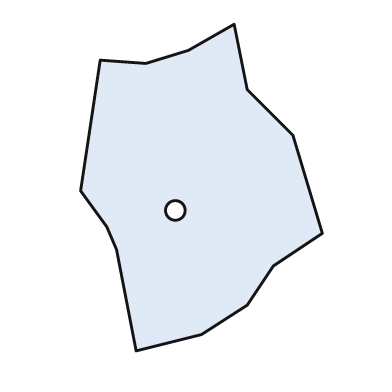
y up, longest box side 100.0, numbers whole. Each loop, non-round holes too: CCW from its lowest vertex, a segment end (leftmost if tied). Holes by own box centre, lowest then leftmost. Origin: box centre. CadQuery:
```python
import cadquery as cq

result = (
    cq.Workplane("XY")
    .moveTo(-20.0, -50.0)
    .lineTo(0.0, -45.0)
    .lineTo(14.0, -36.0)
    .lineTo(22.0, -24.0)
    .lineTo(37.0, -14.0)
    .lineTo(28.0, 16.0)
    .lineTo(14.0, 30.0)
    .lineTo(10.0, 50.0)
    .lineTo(-4.0, 42.0)
    .lineTo(-17.0, 38.0)
    .lineTo(-31.0, 39.0)
    .lineTo(-37.0, -1.0)
    .lineTo(-29.0, -12.0)
    .lineTo(-26.0, -19.0)
    .close()
    .moveTo(-8.0, -7.0)
    .circle(3.0)
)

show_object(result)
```